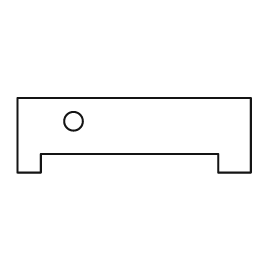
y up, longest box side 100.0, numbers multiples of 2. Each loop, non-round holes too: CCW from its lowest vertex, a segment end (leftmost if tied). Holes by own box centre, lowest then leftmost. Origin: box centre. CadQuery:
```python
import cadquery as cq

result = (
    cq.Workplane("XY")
    .moveTo(-50.0, -16.0)
    .lineTo(-40.0, -16.0)
    .lineTo(-40.0, -8.0)
    .lineTo(36.0, -8.0)
    .lineTo(36.0, -16.0)
    .lineTo(50.0, -16.0)
    .lineTo(50.0, 16.0)
    .lineTo(-50.0, 16.0)
    .close()
    .moveTo(-26.0, 6.0)
    .circle(4.0)
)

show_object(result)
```